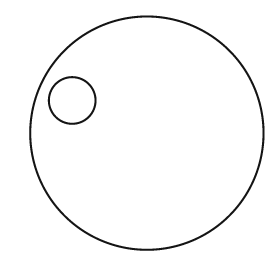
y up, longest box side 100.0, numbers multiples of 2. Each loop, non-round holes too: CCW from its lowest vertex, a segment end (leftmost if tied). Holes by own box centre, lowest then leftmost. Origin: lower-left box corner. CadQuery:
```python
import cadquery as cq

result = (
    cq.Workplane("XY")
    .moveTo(50.0, 50.0)
    .circle(50.0)
    .moveTo(18.0, 64.0)
    .circle(10.0)
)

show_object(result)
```